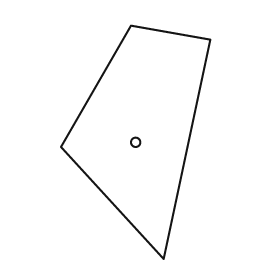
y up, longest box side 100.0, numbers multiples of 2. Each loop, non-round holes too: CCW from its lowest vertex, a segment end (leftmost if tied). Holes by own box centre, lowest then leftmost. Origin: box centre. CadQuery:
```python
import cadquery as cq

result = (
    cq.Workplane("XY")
    .moveTo(12.0, -50.0)
    .lineTo(32.0, 44.0)
    .lineTo(-2.0, 50.0)
    .lineTo(-32.0, -2.0)
    .close()
    .moveTo(0.0, 0.0)
    .circle(2.0)
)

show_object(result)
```